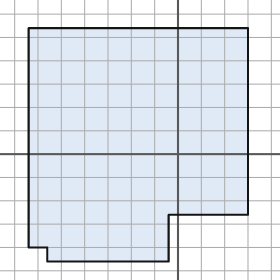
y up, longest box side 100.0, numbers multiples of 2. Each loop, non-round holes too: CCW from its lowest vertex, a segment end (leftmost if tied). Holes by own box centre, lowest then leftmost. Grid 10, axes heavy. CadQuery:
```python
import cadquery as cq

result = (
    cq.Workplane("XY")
    .moveTo(-56.0, -46.0)
    .lineTo(-4.0, -46.0)
    .lineTo(-4.0, -26.0)
    .lineTo(30.0, -26.0)
    .lineTo(30.0, 54.0)
    .lineTo(-64.0, 54.0)
    .lineTo(-64.0, -40.0)
    .lineTo(-56.0, -40.0)
    .close()
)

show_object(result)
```